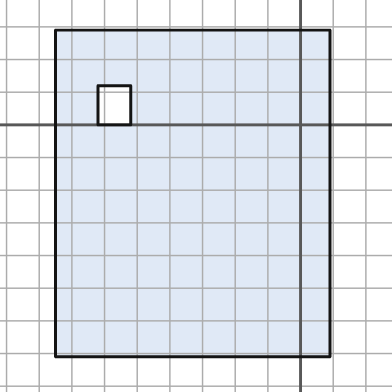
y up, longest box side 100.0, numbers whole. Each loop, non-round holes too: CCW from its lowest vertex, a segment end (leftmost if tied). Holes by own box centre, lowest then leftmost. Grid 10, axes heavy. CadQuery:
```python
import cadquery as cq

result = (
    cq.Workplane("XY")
    .moveTo(-75.0, -71.0)
    .lineTo(9.0, -71.0)
    .lineTo(9.0, 29.0)
    .lineTo(-75.0, 29.0)
    .close()
    .moveTo(-62.0, 0.0)
    .lineTo(-52.0, 0.0)
    .lineTo(-52.0, 12.0)
    .lineTo(-62.0, 12.0)
    .close()
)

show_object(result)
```